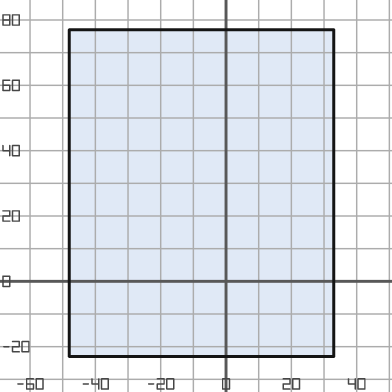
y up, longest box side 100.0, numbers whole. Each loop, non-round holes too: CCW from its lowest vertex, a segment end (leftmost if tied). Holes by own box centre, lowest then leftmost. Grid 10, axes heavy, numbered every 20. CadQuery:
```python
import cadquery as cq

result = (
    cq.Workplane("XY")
    .moveTo(-48.0, -23.0)
    .lineTo(33.0, -23.0)
    .lineTo(33.0, 77.0)
    .lineTo(-48.0, 77.0)
    .close()
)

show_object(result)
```